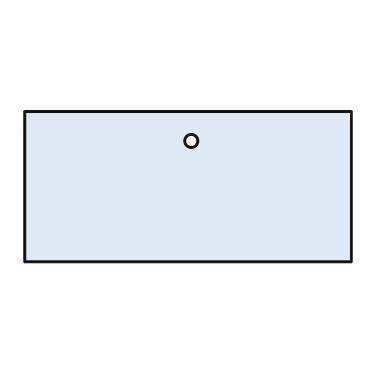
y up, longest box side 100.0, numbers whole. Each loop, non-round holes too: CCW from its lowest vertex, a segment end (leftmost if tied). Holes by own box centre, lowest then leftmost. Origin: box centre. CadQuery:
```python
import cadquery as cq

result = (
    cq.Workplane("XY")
    .moveTo(-50.0, -23.0)
    .lineTo(50.0, -23.0)
    .lineTo(50.0, 23.0)
    .lineTo(-50.0, 23.0)
    .close()
    .moveTo(1.0, 14.0)
    .circle(2.0)
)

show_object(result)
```